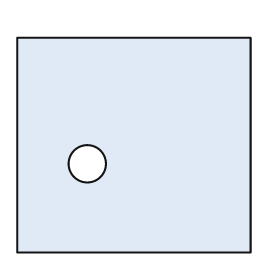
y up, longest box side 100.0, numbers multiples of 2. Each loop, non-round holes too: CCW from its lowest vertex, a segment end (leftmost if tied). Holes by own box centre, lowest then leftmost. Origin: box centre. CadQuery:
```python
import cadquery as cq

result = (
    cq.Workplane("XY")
    .moveTo(-50.0, -46.0)
    .lineTo(50.0, -46.0)
    .lineTo(50.0, 46.0)
    .lineTo(-50.0, 46.0)
    .close()
    .moveTo(-20.0, -8.0)
    .circle(8.0)
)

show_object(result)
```